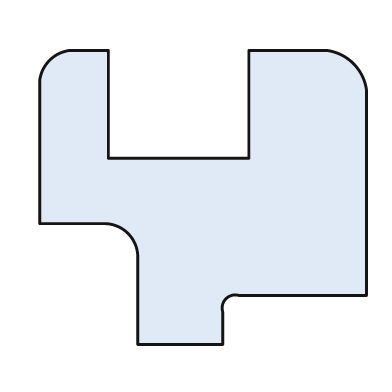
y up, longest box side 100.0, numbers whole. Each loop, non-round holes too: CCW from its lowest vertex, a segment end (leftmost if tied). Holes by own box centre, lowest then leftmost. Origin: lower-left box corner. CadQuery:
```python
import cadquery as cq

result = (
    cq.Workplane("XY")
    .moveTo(30.0, 0.0)
    .lineTo(56.0, 0.0)
    .lineTo(56.0, 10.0)
    .threePointArc((57.0, 14.0), (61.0, 15.0))
    .lineTo(100.0, 15.0)
    .lineTo(100.0, 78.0)
    .threePointArc((96.0, 86.0), (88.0, 90.0))
    .lineTo(64.0, 90.0)
    .lineTo(64.0, 57.0)
    .lineTo(21.0, 57.0)
    .lineTo(21.0, 90.0)
    .lineTo(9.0, 90.0)
    .threePointArc((3.0, 87.0), (0.0, 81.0))
    .lineTo(0.0, 37.0)
    .lineTo(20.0, 37.0)
    .threePointArc((27.0, 34.0), (30.0, 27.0))
    .close()
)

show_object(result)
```